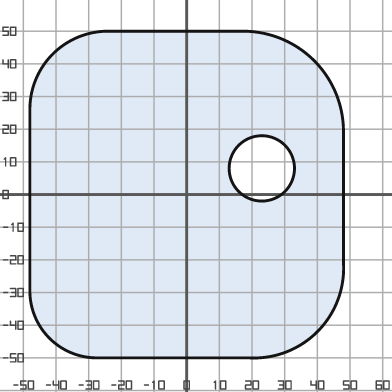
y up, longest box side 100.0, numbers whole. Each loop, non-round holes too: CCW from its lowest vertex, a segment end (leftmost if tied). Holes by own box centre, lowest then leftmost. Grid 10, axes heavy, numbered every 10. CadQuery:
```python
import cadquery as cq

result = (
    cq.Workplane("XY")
    .moveTo(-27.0, -50.0)
    .lineTo(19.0, -50.0)
    .threePointArc((40.0, -42.0), (48.0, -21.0))
    .lineTo(48.0, 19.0)
    .threePointArc((39.0, 41.0), (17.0, 50.0))
    .lineTo(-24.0, 50.0)
    .threePointArc((-41.0, 43.0), (-48.0, 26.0))
    .lineTo(-48.0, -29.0)
    .threePointArc((-42.0, -44.0), (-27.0, -50.0))
    .close()
    .moveTo(23.0, 8.0)
    .circle(10.0)
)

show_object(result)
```